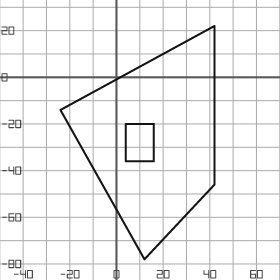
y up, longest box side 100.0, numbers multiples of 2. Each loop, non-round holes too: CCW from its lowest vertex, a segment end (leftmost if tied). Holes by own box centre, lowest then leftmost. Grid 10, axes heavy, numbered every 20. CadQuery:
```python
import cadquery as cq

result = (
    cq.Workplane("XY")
    .moveTo(12.0, -78.0)
    .lineTo(42.0, -46.0)
    .lineTo(42.0, 22.0)
    .lineTo(-24.0, -14.0)
    .close()
    .moveTo(4.0, -36.0)
    .lineTo(16.0, -36.0)
    .lineTo(16.0, -20.0)
    .lineTo(4.0, -20.0)
    .close()
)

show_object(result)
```